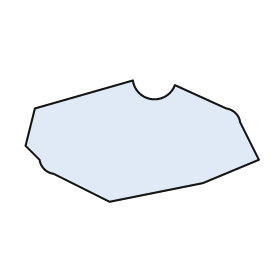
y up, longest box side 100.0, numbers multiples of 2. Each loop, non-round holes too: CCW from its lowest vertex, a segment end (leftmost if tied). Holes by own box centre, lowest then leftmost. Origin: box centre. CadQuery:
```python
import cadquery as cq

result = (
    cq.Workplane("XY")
    .moveTo(-14.0, -26.0)
    .lineTo(26.0, -18.0)
    .lineTo(50.0, -8.0)
    .lineTo(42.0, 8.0)
    .threePointArc((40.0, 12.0), (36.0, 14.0))
    .lineTo(14.0, 24.0)
    .threePointArc((4.0, 18.0), (-4.0, 26.0))
    .lineTo(-46.0, 14.0)
    .lineTo(-50.0, -2.0)
    .lineTo(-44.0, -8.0)
    .threePointArc((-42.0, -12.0), (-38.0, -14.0))
    .close()
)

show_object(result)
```